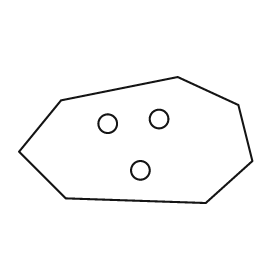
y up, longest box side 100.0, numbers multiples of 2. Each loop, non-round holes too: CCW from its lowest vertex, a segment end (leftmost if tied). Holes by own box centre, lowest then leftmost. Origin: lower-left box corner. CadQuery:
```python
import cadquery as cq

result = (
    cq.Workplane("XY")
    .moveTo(80.0, 0.0)
    .lineTo(100.0, 18.0)
    .lineTo(94.0, 42.0)
    .lineTo(68.0, 54.0)
    .lineTo(18.0, 44.0)
    .lineTo(0.0, 22.0)
    .lineTo(20.0, 2.0)
    .close()
    .moveTo(52.0, 14.0)
    .circle(4.0)
    .moveTo(38.0, 34.0)
    .circle(4.0)
    .moveTo(60.0, 36.0)
    .circle(4.0)
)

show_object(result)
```